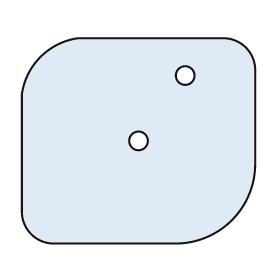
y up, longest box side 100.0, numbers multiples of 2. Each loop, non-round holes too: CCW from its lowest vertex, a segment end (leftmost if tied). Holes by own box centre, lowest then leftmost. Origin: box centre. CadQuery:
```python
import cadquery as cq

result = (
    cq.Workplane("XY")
    .moveTo(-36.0, -44.0)
    .lineTo(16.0, -44.0)
    .threePointArc((40.0, -34.0), (50.0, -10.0))
    .lineTo(50.0, 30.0)
    .threePointArc((46.0, 40.0), (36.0, 44.0))
    .lineTo(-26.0, 44.0)
    .threePointArc((-42.0, 36.0), (-50.0, 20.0))
    .lineTo(-50.0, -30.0)
    .threePointArc((-46.0, -40.0), (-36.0, -44.0))
    .close()
    .moveTo(0.0, 0.0)
    .circle(4.0)
    .moveTo(20.0, 28.0)
    .circle(4.0)
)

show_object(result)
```